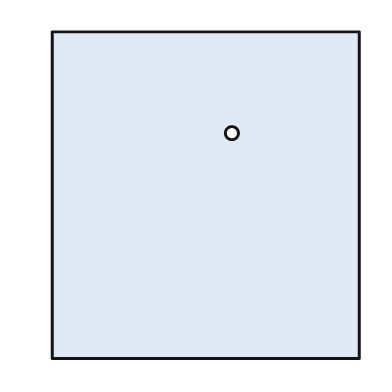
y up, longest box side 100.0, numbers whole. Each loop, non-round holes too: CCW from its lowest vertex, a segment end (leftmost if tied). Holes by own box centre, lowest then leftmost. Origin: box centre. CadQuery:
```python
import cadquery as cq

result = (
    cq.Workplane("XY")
    .moveTo(-47.0, -50.0)
    .lineTo(47.0, -50.0)
    .lineTo(47.0, 50.0)
    .lineTo(-47.0, 50.0)
    .close()
    .moveTo(8.0, 19.0)
    .circle(2.0)
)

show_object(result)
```